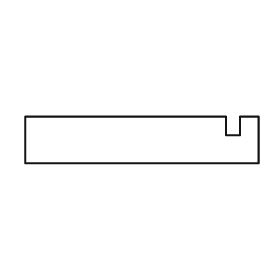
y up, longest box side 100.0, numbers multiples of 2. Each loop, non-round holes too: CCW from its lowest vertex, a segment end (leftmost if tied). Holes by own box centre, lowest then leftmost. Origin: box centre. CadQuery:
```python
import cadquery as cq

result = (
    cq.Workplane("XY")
    .moveTo(-50.0, -10.0)
    .lineTo(50.0, -10.0)
    .lineTo(50.0, 10.0)
    .lineTo(42.0, 10.0)
    .lineTo(42.0, 2.0)
    .lineTo(36.0, 2.0)
    .lineTo(36.0, 10.0)
    .lineTo(-50.0, 10.0)
    .close()
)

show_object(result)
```